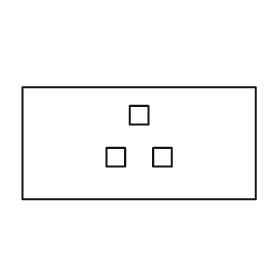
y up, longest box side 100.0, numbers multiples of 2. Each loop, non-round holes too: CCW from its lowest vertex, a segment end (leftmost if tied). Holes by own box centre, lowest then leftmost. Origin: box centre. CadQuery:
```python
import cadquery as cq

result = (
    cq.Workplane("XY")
    .moveTo(-50.0, -24.0)
    .lineTo(50.0, -24.0)
    .lineTo(50.0, 24.0)
    .lineTo(-50.0, 24.0)
    .close()
    .moveTo(-14.0, -10.0)
    .lineTo(-6.0, -10.0)
    .lineTo(-6.0, -2.0)
    .lineTo(-14.0, -2.0)
    .close()
    .moveTo(6.0, -10.0)
    .lineTo(14.0, -10.0)
    .lineTo(14.0, -2.0)
    .lineTo(6.0, -2.0)
    .close()
    .moveTo(-4.0, 8.0)
    .lineTo(4.0, 8.0)
    .lineTo(4.0, 16.0)
    .lineTo(-4.0, 16.0)
    .close()
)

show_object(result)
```